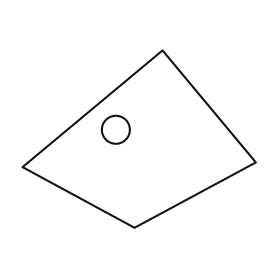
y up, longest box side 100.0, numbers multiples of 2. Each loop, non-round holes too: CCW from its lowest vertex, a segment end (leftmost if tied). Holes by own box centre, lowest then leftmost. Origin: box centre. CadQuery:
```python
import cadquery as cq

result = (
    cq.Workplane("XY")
    .moveTo(-2.0, -38.0)
    .lineTo(50.0, -10.0)
    .lineTo(10.0, 38.0)
    .lineTo(-50.0, -12.0)
    .close()
    .moveTo(-10.0, 4.0)
    .circle(6.0)
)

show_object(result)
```